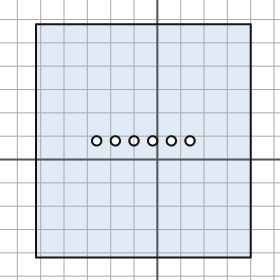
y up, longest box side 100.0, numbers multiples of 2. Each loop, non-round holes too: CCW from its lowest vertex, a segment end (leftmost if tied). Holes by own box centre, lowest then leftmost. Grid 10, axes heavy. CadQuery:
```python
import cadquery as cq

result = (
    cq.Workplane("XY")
    .moveTo(-52.0, -42.0)
    .lineTo(40.0, -42.0)
    .lineTo(40.0, 58.0)
    .lineTo(-52.0, 58.0)
    .close()
    .moveTo(-26.0, 8.0)
    .circle(2.0)
    .moveTo(-18.0, 8.0)
    .circle(2.0)
    .moveTo(-10.0, 8.0)
    .circle(2.0)
    .moveTo(-2.0, 8.0)
    .circle(2.0)
    .moveTo(6.0, 8.0)
    .circle(2.0)
    .moveTo(14.0, 8.0)
    .circle(2.0)
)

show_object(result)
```